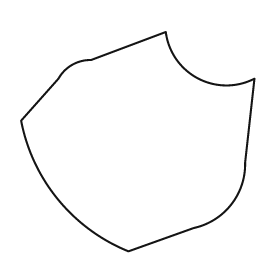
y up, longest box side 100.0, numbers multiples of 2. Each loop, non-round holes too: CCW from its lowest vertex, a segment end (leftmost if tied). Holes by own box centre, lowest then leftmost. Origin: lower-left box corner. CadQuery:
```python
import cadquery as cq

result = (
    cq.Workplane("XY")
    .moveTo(46.0, 0.0)
    .lineTo(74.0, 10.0)
    .threePointArc((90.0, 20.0), (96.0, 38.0))
    .lineTo(100.0, 74.0)
    .threePointArc((76.0, 74.0), (62.0, 94.0))
    .lineTo(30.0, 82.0)
    .threePointArc((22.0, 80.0), (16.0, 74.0))
    .lineTo(0.0, 56.0)
    .threePointArc((16.0, 22.0), (46.0, 0.0))
    .close()
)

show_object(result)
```